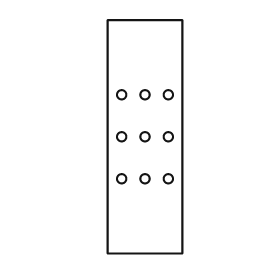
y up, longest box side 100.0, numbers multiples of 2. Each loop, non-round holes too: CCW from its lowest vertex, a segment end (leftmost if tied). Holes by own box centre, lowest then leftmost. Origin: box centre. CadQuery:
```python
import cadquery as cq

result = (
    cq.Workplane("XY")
    .moveTo(-16.0, -50.0)
    .lineTo(16.0, -50.0)
    .lineTo(16.0, 50.0)
    .lineTo(-16.0, 50.0)
    .close()
    .moveTo(-10.0, -18.0)
    .circle(2.0)
    .moveTo(0.0, -18.0)
    .circle(2.0)
    .moveTo(10.0, -18.0)
    .circle(2.0)
    .moveTo(-10.0, 0.0)
    .circle(2.0)
    .moveTo(0.0, 0.0)
    .circle(2.0)
    .moveTo(10.0, 0.0)
    .circle(2.0)
    .moveTo(-10.0, 18.0)
    .circle(2.0)
    .moveTo(0.0, 18.0)
    .circle(2.0)
    .moveTo(10.0, 18.0)
    .circle(2.0)
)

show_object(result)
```